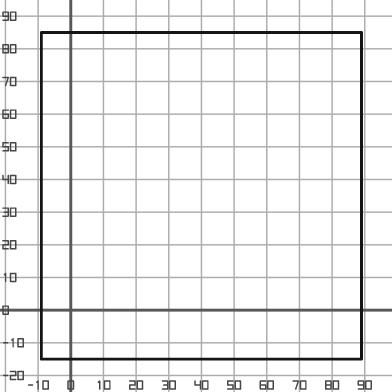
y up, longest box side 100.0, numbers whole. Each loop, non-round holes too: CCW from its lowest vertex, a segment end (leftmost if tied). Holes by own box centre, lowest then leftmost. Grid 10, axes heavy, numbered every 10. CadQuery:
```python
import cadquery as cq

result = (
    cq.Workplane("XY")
    .moveTo(-9.0, -15.0)
    .lineTo(89.0, -15.0)
    .lineTo(89.0, 85.0)
    .lineTo(-9.0, 85.0)
    .close()
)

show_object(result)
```